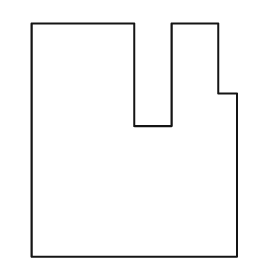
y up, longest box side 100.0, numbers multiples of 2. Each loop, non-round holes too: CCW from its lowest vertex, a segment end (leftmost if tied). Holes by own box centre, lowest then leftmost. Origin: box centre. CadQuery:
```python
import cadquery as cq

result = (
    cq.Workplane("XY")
    .moveTo(-44.0, -50.0)
    .lineTo(44.0, -50.0)
    .lineTo(44.0, 20.0)
    .lineTo(36.0, 20.0)
    .lineTo(36.0, 50.0)
    .lineTo(16.0, 50.0)
    .lineTo(16.0, 6.0)
    .lineTo(0.0, 6.0)
    .lineTo(0.0, 50.0)
    .lineTo(-44.0, 50.0)
    .close()
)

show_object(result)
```